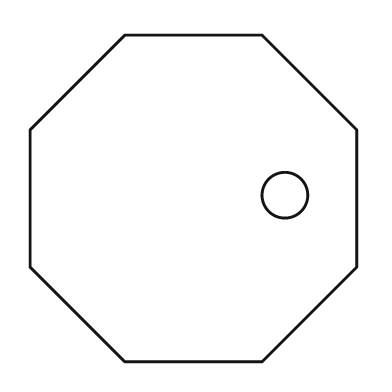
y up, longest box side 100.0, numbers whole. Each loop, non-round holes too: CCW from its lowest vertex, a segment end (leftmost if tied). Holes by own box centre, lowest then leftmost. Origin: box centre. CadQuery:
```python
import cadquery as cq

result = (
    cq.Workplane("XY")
    .moveTo(-21.0, -50.0)
    .lineTo(21.0, -50.0)
    .lineTo(50.0, -21.0)
    .lineTo(50.0, 21.0)
    .lineTo(21.0, 50.0)
    .lineTo(-21.0, 50.0)
    .lineTo(-50.0, 21.0)
    .lineTo(-50.0, -21.0)
    .close()
    .moveTo(28.0, 1.0)
    .circle(7.0)
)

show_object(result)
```